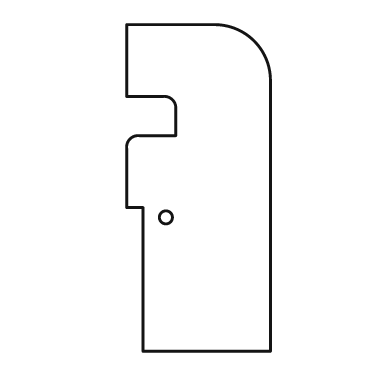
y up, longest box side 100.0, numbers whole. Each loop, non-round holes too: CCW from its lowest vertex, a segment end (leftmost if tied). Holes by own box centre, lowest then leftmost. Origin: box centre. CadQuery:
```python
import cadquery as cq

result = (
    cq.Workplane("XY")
    .moveTo(-17.0, -50.0)
    .lineTo(22.0, -50.0)
    .lineTo(22.0, 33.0)
    .threePointArc((17.0, 45.0), (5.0, 50.0))
    .lineTo(-22.0, 50.0)
    .lineTo(-22.0, 28.0)
    .lineTo(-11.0, 28.0)
    .threePointArc((-8.0, 27.0), (-7.0, 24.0))
    .lineTo(-7.0, 16.0)
    .lineTo(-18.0, 16.0)
    .threePointArc((-21.0, 15.0), (-22.0, 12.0))
    .lineTo(-22.0, -6.0)
    .lineTo(-17.0, -6.0)
    .close()
    .moveTo(-10.0, -9.0)
    .circle(2.0)
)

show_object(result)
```